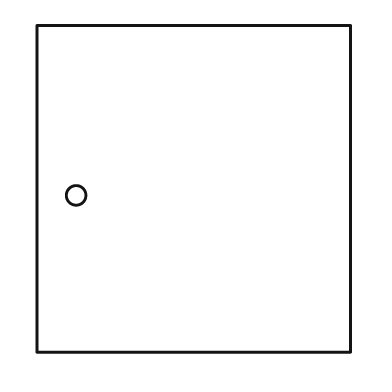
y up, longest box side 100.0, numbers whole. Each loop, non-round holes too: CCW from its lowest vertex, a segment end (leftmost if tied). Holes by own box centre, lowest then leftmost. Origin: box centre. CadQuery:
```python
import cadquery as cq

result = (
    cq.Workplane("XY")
    .moveTo(-48.0, -50.0)
    .lineTo(48.0, -50.0)
    .lineTo(48.0, 50.0)
    .lineTo(-48.0, 50.0)
    .close()
    .moveTo(-36.0, -2.0)
    .circle(3.0)
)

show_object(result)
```